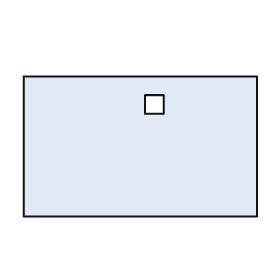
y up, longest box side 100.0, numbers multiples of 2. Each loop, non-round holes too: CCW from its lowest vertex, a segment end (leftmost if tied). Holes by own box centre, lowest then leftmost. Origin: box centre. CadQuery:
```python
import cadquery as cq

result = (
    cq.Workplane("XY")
    .moveTo(-50.0, -30.0)
    .lineTo(50.0, -30.0)
    .lineTo(50.0, 30.0)
    .lineTo(-50.0, 30.0)
    .close()
    .moveTo(2.0, 14.0)
    .lineTo(10.0, 14.0)
    .lineTo(10.0, 22.0)
    .lineTo(2.0, 22.0)
    .close()
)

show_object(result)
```